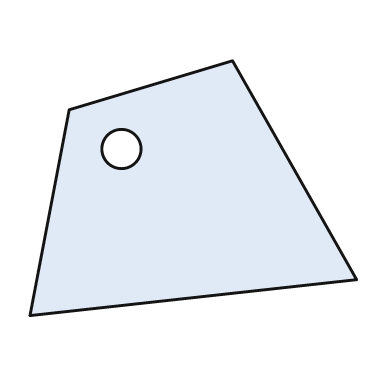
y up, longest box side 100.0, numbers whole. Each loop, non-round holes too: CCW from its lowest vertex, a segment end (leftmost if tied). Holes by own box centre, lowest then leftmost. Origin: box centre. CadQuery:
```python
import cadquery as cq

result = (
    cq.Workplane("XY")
    .moveTo(-50.0, -39.0)
    .lineTo(50.0, -28.0)
    .lineTo(12.0, 39.0)
    .lineTo(-38.0, 24.0)
    .close()
    .moveTo(-22.0, 12.0)
    .circle(6.0)
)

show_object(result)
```